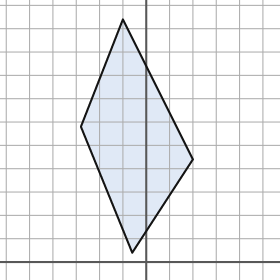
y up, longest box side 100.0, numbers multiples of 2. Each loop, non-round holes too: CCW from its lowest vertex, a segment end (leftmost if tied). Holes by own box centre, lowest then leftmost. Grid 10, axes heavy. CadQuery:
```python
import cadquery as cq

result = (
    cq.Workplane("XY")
    .moveTo(-6.0, 4.0)
    .lineTo(20.0, 44.0)
    .lineTo(-10.0, 104.0)
    .lineTo(-28.0, 58.0)
    .close()
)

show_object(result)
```